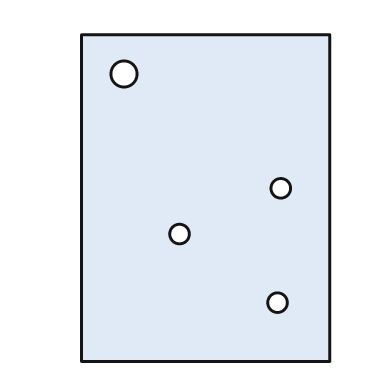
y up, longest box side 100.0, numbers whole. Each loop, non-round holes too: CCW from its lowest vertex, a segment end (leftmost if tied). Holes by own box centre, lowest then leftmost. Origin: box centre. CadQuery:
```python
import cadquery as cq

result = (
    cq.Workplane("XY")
    .moveTo(-38.0, -50.0)
    .lineTo(38.0, -50.0)
    .lineTo(38.0, 50.0)
    .lineTo(-38.0, 50.0)
    .close()
    .moveTo(22.0, -32.0)
    .circle(3.0)
    .moveTo(-8.0, -11.0)
    .circle(3.0)
    .moveTo(23.0, 3.0)
    .circle(3.0)
    .moveTo(-25.0, 38.0)
    .circle(4.0)
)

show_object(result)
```